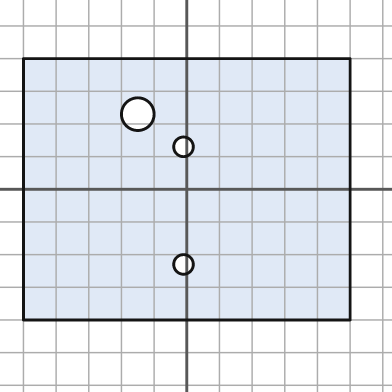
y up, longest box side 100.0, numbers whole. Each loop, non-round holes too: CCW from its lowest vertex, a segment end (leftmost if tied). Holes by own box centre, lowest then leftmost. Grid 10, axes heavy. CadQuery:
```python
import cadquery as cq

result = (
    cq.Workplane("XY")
    .moveTo(-50.0, -40.0)
    .lineTo(50.0, -40.0)
    .lineTo(50.0, 40.0)
    .lineTo(-50.0, 40.0)
    .close()
    .moveTo(-1.0, -23.0)
    .circle(3.0)
    .moveTo(-1.0, 13.0)
    .circle(3.0)
    .moveTo(-15.0, 23.0)
    .circle(5.0)
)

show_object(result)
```